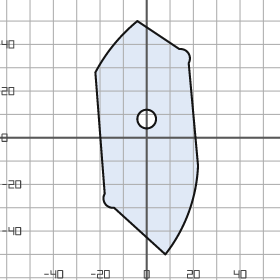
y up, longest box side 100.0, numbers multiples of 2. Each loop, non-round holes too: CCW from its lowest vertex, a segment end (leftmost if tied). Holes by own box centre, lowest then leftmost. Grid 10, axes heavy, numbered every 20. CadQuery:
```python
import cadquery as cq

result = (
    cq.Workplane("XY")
    .moveTo(8.0, -50.0)
    .threePointArc((18.0, -32.0), (22.0, -12.0))
    .lineTo(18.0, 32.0)
    .threePointArc((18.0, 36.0), (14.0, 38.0))
    .lineTo(-4.0, 50.0)
    .threePointArc((-14.0, 40.0), (-22.0, 28.0))
    .lineTo(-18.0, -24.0)
    .threePointArc((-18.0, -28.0), (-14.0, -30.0))
    .close()
    .moveTo(0.0, 8.0)
    .circle(4.0)
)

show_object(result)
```